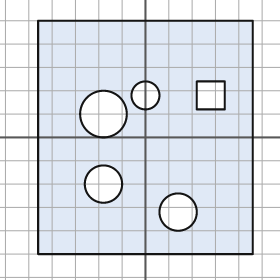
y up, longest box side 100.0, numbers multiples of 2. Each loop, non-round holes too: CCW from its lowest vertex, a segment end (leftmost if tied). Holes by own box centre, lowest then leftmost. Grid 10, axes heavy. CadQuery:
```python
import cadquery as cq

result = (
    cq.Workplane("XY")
    .moveTo(-46.0, -50.0)
    .lineTo(46.0, -50.0)
    .lineTo(46.0, 50.0)
    .lineTo(-46.0, 50.0)
    .close()
    .moveTo(14.0, -32.0)
    .circle(8.0)
    .moveTo(-18.0, -20.0)
    .circle(8.0)
    .moveTo(-18.0, 10.0)
    .circle(10.0)
    .moveTo(0.0, 18.0)
    .circle(6.0)
    .moveTo(22.0, 12.0)
    .lineTo(34.0, 12.0)
    .lineTo(34.0, 24.0)
    .lineTo(22.0, 24.0)
    .close()
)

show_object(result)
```